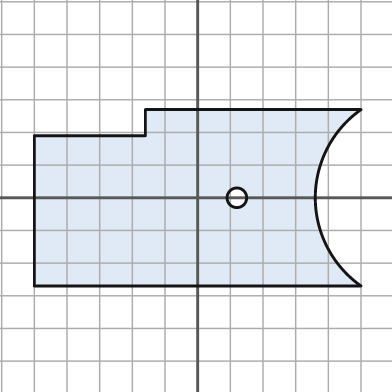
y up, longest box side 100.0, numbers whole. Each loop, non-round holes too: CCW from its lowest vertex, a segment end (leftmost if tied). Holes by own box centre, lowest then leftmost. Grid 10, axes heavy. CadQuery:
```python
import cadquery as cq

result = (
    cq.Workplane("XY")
    .moveTo(-50.0, -27.0)
    .lineTo(50.0, -27.0)
    .threePointArc((36.0, 0.0), (50.0, 27.0))
    .lineTo(-16.0, 27.0)
    .lineTo(-16.0, 19.0)
    .lineTo(-50.0, 19.0)
    .close()
    .moveTo(12.0, 0.0)
    .circle(3.0)
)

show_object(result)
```